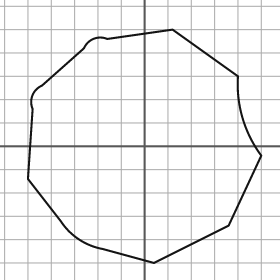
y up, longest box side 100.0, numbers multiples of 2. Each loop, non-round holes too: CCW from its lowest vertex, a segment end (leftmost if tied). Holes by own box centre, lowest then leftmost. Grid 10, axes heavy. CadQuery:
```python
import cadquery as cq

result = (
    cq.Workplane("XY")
    .moveTo(4.0, -50.0)
    .lineTo(36.0, -34.0)
    .lineTo(50.0, -4.0)
    .threePointArc((42.0, 12.0), (40.0, 30.0))
    .lineTo(12.0, 50.0)
    .lineTo(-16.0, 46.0)
    .threePointArc((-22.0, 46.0), (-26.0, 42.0))
    .lineTo(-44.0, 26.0)
    .threePointArc((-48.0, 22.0), (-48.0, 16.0))
    .lineTo(-50.0, -14.0)
    .lineTo(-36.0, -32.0)
    .threePointArc((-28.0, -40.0), (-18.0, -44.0))
    .close()
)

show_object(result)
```